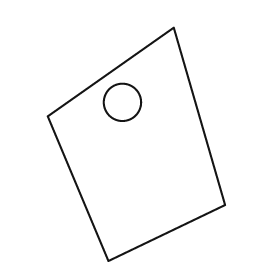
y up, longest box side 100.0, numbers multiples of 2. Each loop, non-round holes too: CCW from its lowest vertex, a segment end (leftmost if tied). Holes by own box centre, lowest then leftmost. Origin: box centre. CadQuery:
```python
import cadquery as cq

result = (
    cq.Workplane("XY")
    .moveTo(-12.0, -50.0)
    .lineTo(38.0, -26.0)
    .lineTo(16.0, 50.0)
    .lineTo(-38.0, 12.0)
    .close()
    .moveTo(-6.0, 18.0)
    .circle(8.0)
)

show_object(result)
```